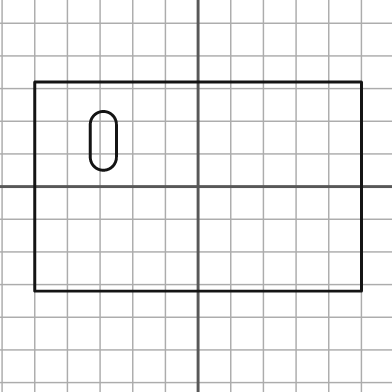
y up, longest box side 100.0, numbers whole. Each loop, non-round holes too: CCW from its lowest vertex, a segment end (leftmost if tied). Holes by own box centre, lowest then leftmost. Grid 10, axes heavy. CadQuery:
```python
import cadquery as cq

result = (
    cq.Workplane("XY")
    .moveTo(-50.0, -32.0)
    .lineTo(50.0, -32.0)
    .lineTo(50.0, 32.0)
    .lineTo(-50.0, 32.0)
    .close()
    .moveTo(-33.0, 9.0)
    .threePointArc((-29.0, 5.0), (-25.0, 9.0))
    .lineTo(-25.0, 19.0)
    .threePointArc((-29.0, 23.0), (-33.0, 19.0))
    .close()
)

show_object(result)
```